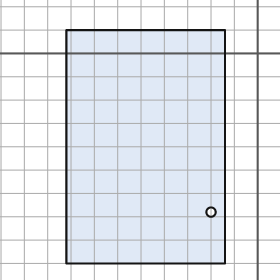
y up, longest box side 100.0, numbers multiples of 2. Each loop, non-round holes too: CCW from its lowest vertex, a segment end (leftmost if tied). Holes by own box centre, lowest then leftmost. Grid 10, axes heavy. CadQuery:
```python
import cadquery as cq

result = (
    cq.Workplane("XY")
    .moveTo(-82.0, -90.0)
    .lineTo(-14.0, -90.0)
    .lineTo(-14.0, 10.0)
    .lineTo(-82.0, 10.0)
    .close()
    .moveTo(-20.0, -68.0)
    .circle(2.0)
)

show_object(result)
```